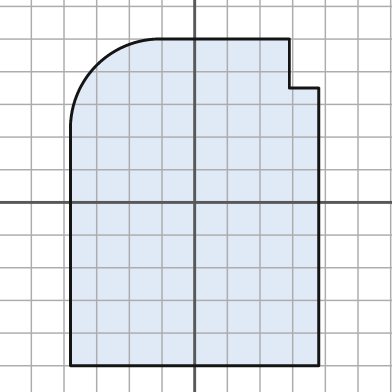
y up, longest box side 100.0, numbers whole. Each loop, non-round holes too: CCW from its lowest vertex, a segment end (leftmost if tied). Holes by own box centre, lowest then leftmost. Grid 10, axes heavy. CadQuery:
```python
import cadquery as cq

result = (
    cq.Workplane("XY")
    .moveTo(-38.0, -50.0)
    .lineTo(38.0, -50.0)
    .lineTo(38.0, 35.0)
    .lineTo(29.0, 35.0)
    .lineTo(29.0, 50.0)
    .lineTo(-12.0, 50.0)
    .threePointArc((-30.0, 42.0), (-38.0, 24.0))
    .close()
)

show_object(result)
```